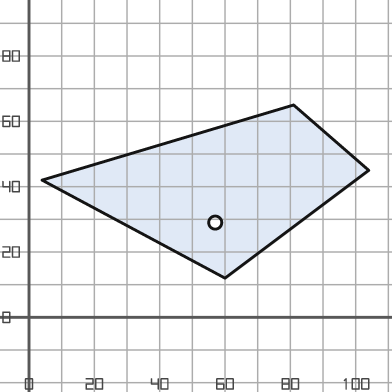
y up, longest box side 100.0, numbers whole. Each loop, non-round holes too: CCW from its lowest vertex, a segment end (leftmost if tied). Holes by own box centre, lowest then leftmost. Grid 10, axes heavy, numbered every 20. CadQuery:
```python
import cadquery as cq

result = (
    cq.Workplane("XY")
    .moveTo(60.0, 12.0)
    .lineTo(104.0, 45.0)
    .lineTo(81.0, 65.0)
    .lineTo(4.0, 42.0)
    .close()
    .moveTo(57.0, 29.0)
    .circle(2.0)
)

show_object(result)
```